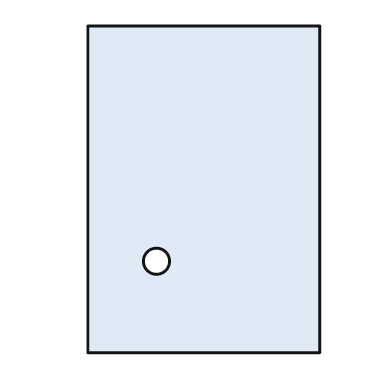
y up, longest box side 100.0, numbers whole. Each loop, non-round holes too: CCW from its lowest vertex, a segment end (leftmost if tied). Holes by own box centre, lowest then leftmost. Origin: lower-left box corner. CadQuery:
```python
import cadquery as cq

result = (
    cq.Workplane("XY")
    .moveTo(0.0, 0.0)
    .lineTo(71.0, 0.0)
    .lineTo(71.0, 100.0)
    .lineTo(0.0, 100.0)
    .close()
    .moveTo(21.0, 28.0)
    .circle(4.0)
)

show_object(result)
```